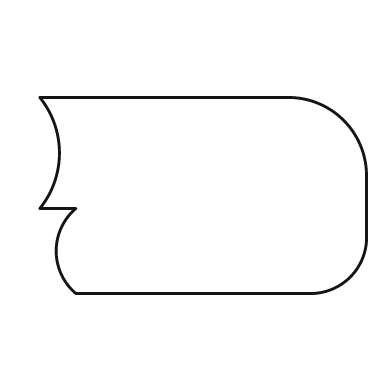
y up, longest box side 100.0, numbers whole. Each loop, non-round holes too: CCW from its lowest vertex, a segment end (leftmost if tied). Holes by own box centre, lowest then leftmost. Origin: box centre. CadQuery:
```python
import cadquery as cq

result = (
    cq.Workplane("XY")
    .moveTo(-39.0, -30.0)
    .lineTo(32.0, -30.0)
    .threePointArc((45.0, -25.0), (50.0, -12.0))
    .lineTo(50.0, 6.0)
    .threePointArc((43.0, 23.0), (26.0, 30.0))
    .lineTo(-50.0, 30.0)
    .threePointArc((-44.0, 13.0), (-50.0, -4.0))
    .lineTo(-39.0, -4.0)
    .threePointArc((-45.0, -17.0), (-39.0, -30.0))
    .close()
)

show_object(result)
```